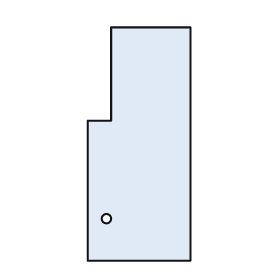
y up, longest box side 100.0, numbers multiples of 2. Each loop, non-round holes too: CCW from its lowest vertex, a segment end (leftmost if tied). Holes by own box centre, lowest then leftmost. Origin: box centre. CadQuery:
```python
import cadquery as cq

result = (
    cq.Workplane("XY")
    .moveTo(-22.0, -50.0)
    .lineTo(22.0, -50.0)
    .lineTo(22.0, 50.0)
    .lineTo(-12.0, 50.0)
    .lineTo(-12.0, 10.0)
    .lineTo(-22.0, 10.0)
    .close()
    .moveTo(-14.0, -32.0)
    .circle(2.0)
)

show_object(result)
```